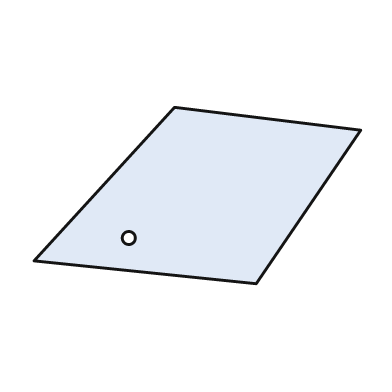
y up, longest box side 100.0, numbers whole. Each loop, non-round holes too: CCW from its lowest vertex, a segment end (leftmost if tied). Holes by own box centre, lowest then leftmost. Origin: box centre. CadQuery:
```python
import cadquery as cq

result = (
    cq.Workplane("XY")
    .moveTo(18.0, -27.0)
    .lineTo(50.0, 20.0)
    .lineTo(-7.0, 27.0)
    .lineTo(-50.0, -20.0)
    .close()
    .moveTo(-21.0, -13.0)
    .circle(2.0)
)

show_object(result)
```